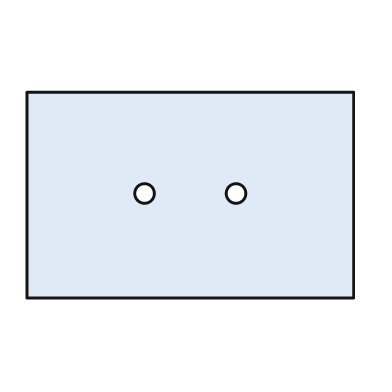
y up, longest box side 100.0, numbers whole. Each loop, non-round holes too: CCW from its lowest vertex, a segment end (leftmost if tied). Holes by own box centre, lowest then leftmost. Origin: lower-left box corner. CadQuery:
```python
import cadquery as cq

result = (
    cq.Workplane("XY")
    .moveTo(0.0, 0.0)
    .lineTo(100.0, 0.0)
    .lineTo(100.0, 63.0)
    .lineTo(0.0, 63.0)
    .close()
    .moveTo(36.0, 32.0)
    .circle(3.0)
    .moveTo(64.0, 32.0)
    .circle(3.0)
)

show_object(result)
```